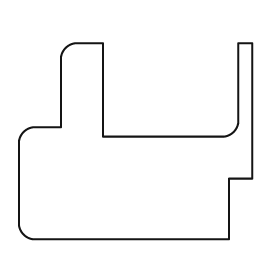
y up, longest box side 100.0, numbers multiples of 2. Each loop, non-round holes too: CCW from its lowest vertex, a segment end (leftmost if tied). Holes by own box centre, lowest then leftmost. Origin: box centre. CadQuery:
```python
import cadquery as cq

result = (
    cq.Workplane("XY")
    .moveTo(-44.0, -42.0)
    .lineTo(40.0, -42.0)
    .lineTo(40.0, -16.0)
    .lineTo(50.0, -16.0)
    .lineTo(50.0, 42.0)
    .lineTo(44.0, 42.0)
    .lineTo(44.0, 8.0)
    .threePointArc((42.0, 4.0), (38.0, 2.0))
    .lineTo(-14.0, 2.0)
    .lineTo(-14.0, 42.0)
    .lineTo(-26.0, 42.0)
    .threePointArc((-30.0, 40.0), (-32.0, 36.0))
    .lineTo(-32.0, 6.0)
    .lineTo(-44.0, 6.0)
    .threePointArc((-48.0, 4.0), (-50.0, 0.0))
    .lineTo(-50.0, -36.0)
    .threePointArc((-48.0, -40.0), (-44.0, -42.0))
    .close()
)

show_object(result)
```